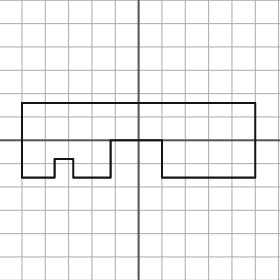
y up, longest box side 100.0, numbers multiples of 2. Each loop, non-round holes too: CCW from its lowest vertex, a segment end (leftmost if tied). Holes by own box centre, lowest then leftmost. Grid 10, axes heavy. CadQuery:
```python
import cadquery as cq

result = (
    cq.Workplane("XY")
    .moveTo(-50.0, -16.0)
    .lineTo(-36.0, -16.0)
    .lineTo(-36.0, -8.0)
    .lineTo(-28.0, -8.0)
    .lineTo(-28.0, -16.0)
    .lineTo(-12.0, -16.0)
    .lineTo(-12.0, 0.0)
    .lineTo(10.0, 0.0)
    .lineTo(10.0, -16.0)
    .lineTo(50.0, -16.0)
    .lineTo(50.0, 16.0)
    .lineTo(-50.0, 16.0)
    .close()
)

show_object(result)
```